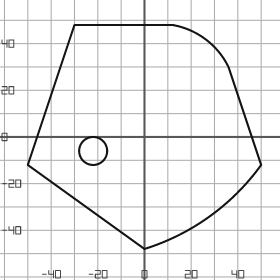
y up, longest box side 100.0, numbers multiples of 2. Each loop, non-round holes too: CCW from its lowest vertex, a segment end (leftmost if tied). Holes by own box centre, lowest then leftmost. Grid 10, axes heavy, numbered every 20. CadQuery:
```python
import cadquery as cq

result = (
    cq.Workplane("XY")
    .moveTo(0.0, -48.0)
    .threePointArc((28.0, -34.0), (50.0, -12.0))
    .lineTo(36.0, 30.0)
    .threePointArc((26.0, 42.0), (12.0, 48.0))
    .lineTo(-30.0, 48.0)
    .lineTo(-50.0, -12.0)
    .close()
    .moveTo(-22.0, -6.0)
    .circle(6.0)
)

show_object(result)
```